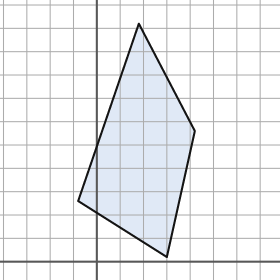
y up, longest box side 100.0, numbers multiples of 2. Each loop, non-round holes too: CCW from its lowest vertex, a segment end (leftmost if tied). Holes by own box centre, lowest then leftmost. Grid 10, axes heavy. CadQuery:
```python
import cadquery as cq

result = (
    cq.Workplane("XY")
    .moveTo(30.0, 2.0)
    .lineTo(42.0, 56.0)
    .lineTo(18.0, 102.0)
    .lineTo(-8.0, 26.0)
    .close()
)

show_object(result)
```